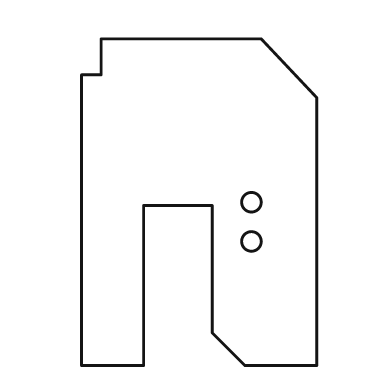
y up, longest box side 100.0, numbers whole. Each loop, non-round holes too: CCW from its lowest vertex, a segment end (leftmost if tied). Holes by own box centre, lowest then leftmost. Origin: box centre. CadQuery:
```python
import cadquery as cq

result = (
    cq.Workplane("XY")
    .moveTo(-36.0, -50.0)
    .lineTo(-17.0, -50.0)
    .lineTo(-17.0, -1.0)
    .lineTo(4.0, -1.0)
    .lineTo(4.0, -40.0)
    .lineTo(14.0, -50.0)
    .lineTo(36.0, -50.0)
    .lineTo(36.0, 32.0)
    .lineTo(19.0, 50.0)
    .lineTo(-30.0, 50.0)
    .lineTo(-30.0, 39.0)
    .lineTo(-36.0, 39.0)
    .close()
    .moveTo(16.0, -12.0)
    .circle(3.0)
    .moveTo(16.0, 0.0)
    .circle(3.0)
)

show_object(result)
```